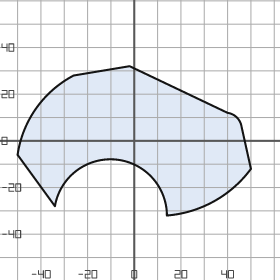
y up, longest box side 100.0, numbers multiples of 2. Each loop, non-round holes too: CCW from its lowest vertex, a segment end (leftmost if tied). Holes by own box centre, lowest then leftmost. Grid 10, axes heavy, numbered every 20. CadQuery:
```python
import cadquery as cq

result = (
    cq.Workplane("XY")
    .moveTo(14.0, -32.0)
    .threePointArc((34.0, -26.0), (50.0, -12.0))
    .lineTo(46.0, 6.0)
    .threePointArc((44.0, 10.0), (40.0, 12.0))
    .lineTo(-2.0, 32.0)
    .lineTo(-26.0, 28.0)
    .threePointArc((-42.0, 14.0), (-50.0, -6.0))
    .lineTo(-34.0, -28.0)
    .threePointArc((-8.0, -8.0), (14.0, -32.0))
    .close()
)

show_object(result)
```